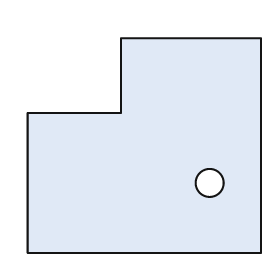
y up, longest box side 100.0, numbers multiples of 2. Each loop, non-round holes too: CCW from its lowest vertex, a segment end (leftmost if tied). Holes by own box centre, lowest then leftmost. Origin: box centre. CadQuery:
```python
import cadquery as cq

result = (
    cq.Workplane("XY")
    .moveTo(-50.0, -46.0)
    .lineTo(50.0, -46.0)
    .lineTo(50.0, 46.0)
    .lineTo(-10.0, 46.0)
    .lineTo(-10.0, 14.0)
    .lineTo(-50.0, 14.0)
    .close()
    .moveTo(28.0, -16.0)
    .circle(6.0)
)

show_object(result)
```